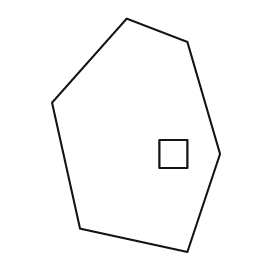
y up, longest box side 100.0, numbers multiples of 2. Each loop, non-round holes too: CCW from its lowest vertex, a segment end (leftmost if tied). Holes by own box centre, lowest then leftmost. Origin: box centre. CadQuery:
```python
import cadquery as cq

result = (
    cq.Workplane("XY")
    .moveTo(22.0, -50.0)
    .lineTo(36.0, -8.0)
    .lineTo(22.0, 40.0)
    .lineTo(-4.0, 50.0)
    .lineTo(-36.0, 14.0)
    .lineTo(-24.0, -40.0)
    .close()
    .moveTo(10.0, -14.0)
    .lineTo(22.0, -14.0)
    .lineTo(22.0, -2.0)
    .lineTo(10.0, -2.0)
    .close()
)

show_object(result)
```